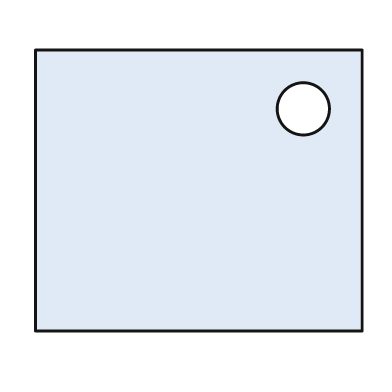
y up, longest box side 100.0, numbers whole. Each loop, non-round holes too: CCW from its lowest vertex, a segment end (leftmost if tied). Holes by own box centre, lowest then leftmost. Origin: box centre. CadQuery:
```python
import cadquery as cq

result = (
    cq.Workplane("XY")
    .moveTo(-50.0, -43.0)
    .lineTo(50.0, -43.0)
    .lineTo(50.0, 43.0)
    .lineTo(-50.0, 43.0)
    .close()
    .moveTo(32.0, 25.0)
    .circle(8.0)
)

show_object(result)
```